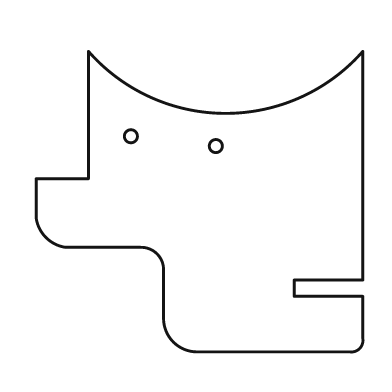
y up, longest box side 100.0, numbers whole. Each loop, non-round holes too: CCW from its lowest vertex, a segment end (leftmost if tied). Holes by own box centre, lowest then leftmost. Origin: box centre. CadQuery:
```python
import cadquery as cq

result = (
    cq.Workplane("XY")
    .moveTo(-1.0, -46.0)
    .lineTo(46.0, -46.0)
    .threePointArc((49.0, -45.0), (50.0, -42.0))
    .lineTo(50.0, -29.0)
    .lineTo(29.0, -29.0)
    .lineTo(29.0, -24.0)
    .lineTo(50.0, -24.0)
    .lineTo(50.0, 46.0)
    .threePointArc((8.0, 27.0), (-34.0, 46.0))
    .lineTo(-34.0, 7.0)
    .lineTo(-50.0, 7.0)
    .lineTo(-50.0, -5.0)
    .threePointArc((-47.0, -11.0), (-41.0, -14.0))
    .lineTo(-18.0, -14.0)
    .threePointArc((-13.0, -16.0), (-11.0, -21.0))
    .lineTo(-11.0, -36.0)
    .threePointArc((-8.0, -43.0), (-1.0, -46.0))
    .close()
    .moveTo(5.0, 17.0)
    .circle(2.0)
    .moveTo(-21.0, 20.0)
    .circle(2.0)
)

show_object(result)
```